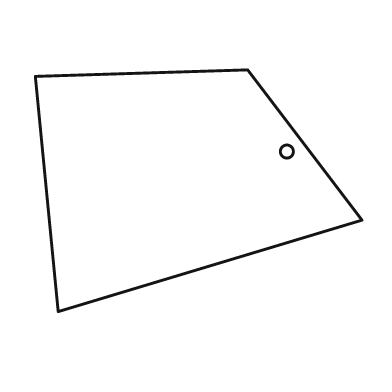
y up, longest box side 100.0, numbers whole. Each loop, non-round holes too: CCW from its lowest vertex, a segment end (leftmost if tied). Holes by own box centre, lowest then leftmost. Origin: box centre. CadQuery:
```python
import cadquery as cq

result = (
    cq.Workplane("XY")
    .moveTo(-43.0, -37.0)
    .lineTo(50.0, -9.0)
    .lineTo(15.0, 37.0)
    .lineTo(-50.0, 35.0)
    .close()
    .moveTo(27.0, 12.0)
    .circle(2.0)
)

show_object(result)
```